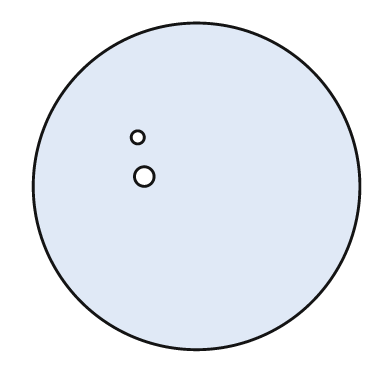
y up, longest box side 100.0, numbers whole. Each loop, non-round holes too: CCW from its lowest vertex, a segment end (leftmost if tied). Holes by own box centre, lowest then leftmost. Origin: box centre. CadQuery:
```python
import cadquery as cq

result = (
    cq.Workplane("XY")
    .moveTo(0.0, 0.0)
    .circle(50.0)
    .moveTo(-16.0, 3.0)
    .circle(3.0)
    .moveTo(-18.0, 15.0)
    .circle(2.0)
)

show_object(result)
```